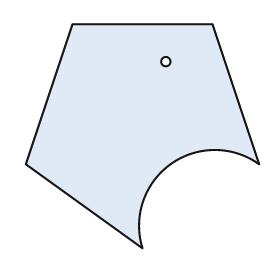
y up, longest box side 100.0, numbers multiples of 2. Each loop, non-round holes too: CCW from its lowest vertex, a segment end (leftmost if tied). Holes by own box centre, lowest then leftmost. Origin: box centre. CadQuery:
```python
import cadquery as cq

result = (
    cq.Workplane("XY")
    .moveTo(0.0, -48.0)
    .threePointArc((12.0, -12.0), (50.0, -12.0))
    .lineTo(30.0, 48.0)
    .lineTo(-30.0, 48.0)
    .lineTo(-50.0, -12.0)
    .close()
    .moveTo(10.0, 32.0)
    .circle(2.0)
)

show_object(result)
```